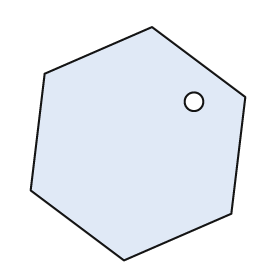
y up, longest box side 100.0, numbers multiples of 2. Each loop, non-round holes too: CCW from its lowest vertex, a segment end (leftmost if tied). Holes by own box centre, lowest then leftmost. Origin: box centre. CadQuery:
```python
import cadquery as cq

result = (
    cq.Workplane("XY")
    .moveTo(-6.0, -50.0)
    .lineTo(40.0, -30.0)
    .lineTo(46.0, 20.0)
    .lineTo(6.0, 50.0)
    .lineTo(-40.0, 30.0)
    .lineTo(-46.0, -20.0)
    .close()
    .moveTo(24.0, 18.0)
    .circle(4.0)
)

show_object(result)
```